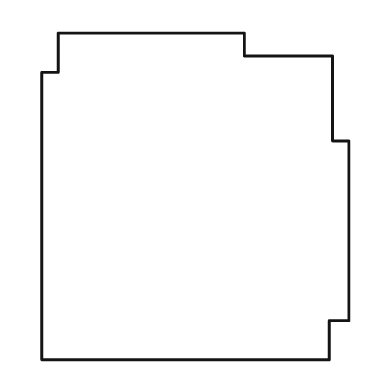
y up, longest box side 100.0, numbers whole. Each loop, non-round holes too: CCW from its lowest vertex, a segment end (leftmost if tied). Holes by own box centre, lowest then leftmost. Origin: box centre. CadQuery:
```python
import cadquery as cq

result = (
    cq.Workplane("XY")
    .moveTo(-47.0, -50.0)
    .lineTo(41.0, -50.0)
    .lineTo(41.0, -38.0)
    .lineTo(47.0, -38.0)
    .lineTo(47.0, 17.0)
    .lineTo(42.0, 17.0)
    .lineTo(42.0, 43.0)
    .lineTo(15.0, 43.0)
    .lineTo(15.0, 50.0)
    .lineTo(-42.0, 50.0)
    .lineTo(-42.0, 38.0)
    .lineTo(-47.0, 38.0)
    .close()
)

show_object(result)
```